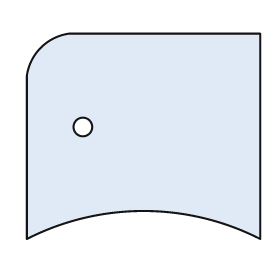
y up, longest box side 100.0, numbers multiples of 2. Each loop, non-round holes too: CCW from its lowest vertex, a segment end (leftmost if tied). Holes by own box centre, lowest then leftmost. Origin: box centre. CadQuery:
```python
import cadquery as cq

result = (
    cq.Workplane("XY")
    .moveTo(-50.0, -44.0)
    .threePointArc((0.0, -32.0), (50.0, -44.0))
    .lineTo(50.0, 44.0)
    .lineTo(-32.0, 44.0)
    .threePointArc((-44.0, 38.0), (-50.0, 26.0))
    .close()
    .moveTo(-26.0, 4.0)
    .circle(4.0)
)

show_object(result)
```